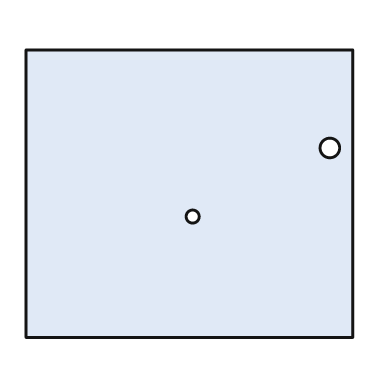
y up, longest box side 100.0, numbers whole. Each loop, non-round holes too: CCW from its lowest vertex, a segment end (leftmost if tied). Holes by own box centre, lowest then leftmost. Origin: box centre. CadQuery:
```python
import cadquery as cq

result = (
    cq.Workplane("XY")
    .moveTo(-50.0, -44.0)
    .lineTo(50.0, -44.0)
    .lineTo(50.0, 44.0)
    .lineTo(-50.0, 44.0)
    .close()
    .moveTo(1.0, -7.0)
    .circle(2.0)
    .moveTo(43.0, 14.0)
    .circle(3.0)
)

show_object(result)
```